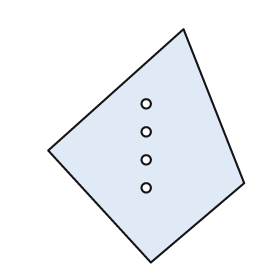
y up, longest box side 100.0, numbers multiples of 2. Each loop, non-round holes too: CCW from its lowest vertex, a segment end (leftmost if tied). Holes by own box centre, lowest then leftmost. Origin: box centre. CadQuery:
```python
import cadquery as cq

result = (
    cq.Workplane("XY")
    .moveTo(2.0, -50.0)
    .lineTo(42.0, -16.0)
    .lineTo(16.0, 50.0)
    .lineTo(-42.0, -2.0)
    .close()
    .moveTo(0.0, -18.0)
    .circle(2.0)
    .moveTo(0.0, -6.0)
    .circle(2.0)
    .moveTo(0.0, 6.0)
    .circle(2.0)
    .moveTo(0.0, 18.0)
    .circle(2.0)
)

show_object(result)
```